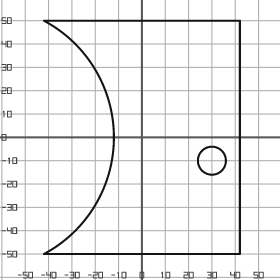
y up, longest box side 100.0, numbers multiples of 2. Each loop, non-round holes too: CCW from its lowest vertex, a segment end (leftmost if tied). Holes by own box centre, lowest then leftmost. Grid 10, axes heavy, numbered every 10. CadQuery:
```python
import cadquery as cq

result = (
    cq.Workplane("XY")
    .moveTo(-42.0, -50.0)
    .lineTo(42.0, -50.0)
    .lineTo(42.0, 50.0)
    .lineTo(-42.0, 50.0)
    .threePointArc((-12.0, 0.0), (-42.0, -50.0))
    .close()
    .moveTo(30.0, -10.0)
    .circle(6.0)
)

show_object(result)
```